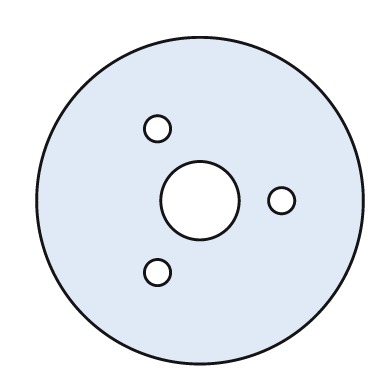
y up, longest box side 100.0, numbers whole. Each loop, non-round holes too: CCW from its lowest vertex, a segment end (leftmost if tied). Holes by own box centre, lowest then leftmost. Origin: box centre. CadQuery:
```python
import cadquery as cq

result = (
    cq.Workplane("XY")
    .moveTo(0.0, 0.0)
    .circle(50.0)
    .moveTo(-13.0, -22.0)
    .circle(4.0)
    .moveTo(0.0, 0.0)
    .circle(12.0)
    .moveTo(25.0, 0.0)
    .circle(4.0)
    .moveTo(-13.0, 22.0)
    .circle(4.0)
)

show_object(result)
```